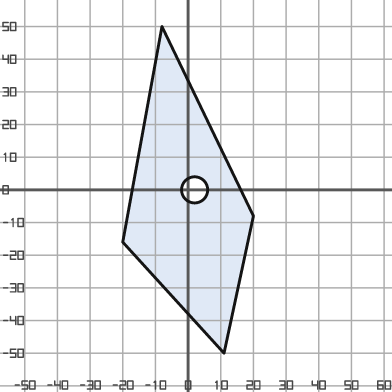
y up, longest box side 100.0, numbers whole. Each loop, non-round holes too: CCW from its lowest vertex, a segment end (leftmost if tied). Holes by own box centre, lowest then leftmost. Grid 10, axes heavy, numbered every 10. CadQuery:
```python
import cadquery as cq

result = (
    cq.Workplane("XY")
    .moveTo(11.0, -50.0)
    .lineTo(20.0, -8.0)
    .lineTo(-8.0, 50.0)
    .lineTo(-20.0, -16.0)
    .close()
    .moveTo(2.0, 0.0)
    .circle(4.0)
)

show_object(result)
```